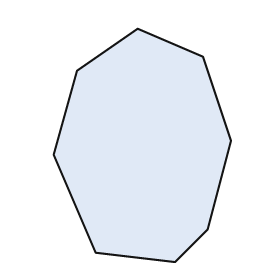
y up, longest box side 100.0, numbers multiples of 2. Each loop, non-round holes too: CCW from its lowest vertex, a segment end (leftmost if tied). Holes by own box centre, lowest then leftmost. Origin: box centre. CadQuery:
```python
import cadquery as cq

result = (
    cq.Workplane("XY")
    .moveTo(14.0, -50.0)
    .lineTo(28.0, -36.0)
    .lineTo(38.0, 2.0)
    .lineTo(26.0, 38.0)
    .lineTo(-2.0, 50.0)
    .lineTo(-28.0, 32.0)
    .lineTo(-38.0, -4.0)
    .lineTo(-20.0, -46.0)
    .close()
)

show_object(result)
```